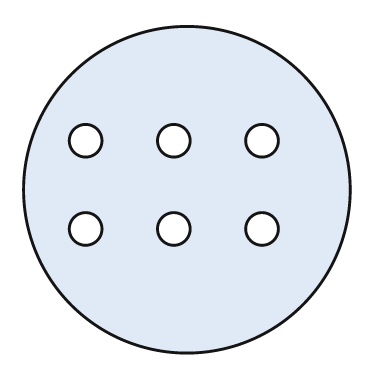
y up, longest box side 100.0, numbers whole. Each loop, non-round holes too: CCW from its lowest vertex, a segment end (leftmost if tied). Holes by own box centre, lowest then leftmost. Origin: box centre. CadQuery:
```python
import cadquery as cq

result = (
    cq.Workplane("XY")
    .moveTo(0.0, 0.0)
    .circle(50.0)
    .moveTo(-31.0, -12.0)
    .circle(5.0)
    .moveTo(-4.0, -12.0)
    .circle(5.0)
    .moveTo(23.0, -12.0)
    .circle(5.0)
    .moveTo(-31.0, 15.0)
    .circle(5.0)
    .moveTo(-4.0, 15.0)
    .circle(5.0)
    .moveTo(23.0, 15.0)
    .circle(5.0)
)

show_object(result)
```